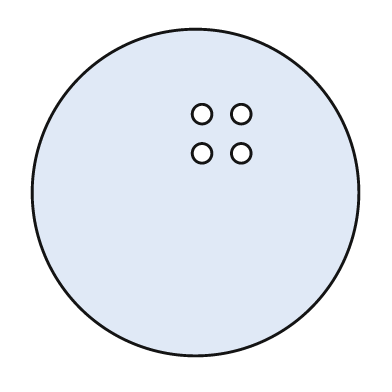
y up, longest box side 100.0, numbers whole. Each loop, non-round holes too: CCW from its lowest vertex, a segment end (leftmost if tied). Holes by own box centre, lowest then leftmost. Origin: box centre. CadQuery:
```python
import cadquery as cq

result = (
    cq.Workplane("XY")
    .moveTo(0.0, 0.0)
    .circle(50.0)
    .moveTo(2.0, 12.0)
    .circle(3.0)
    .moveTo(14.0, 12.0)
    .circle(3.0)
    .moveTo(2.0, 24.0)
    .circle(3.0)
    .moveTo(14.0, 24.0)
    .circle(3.0)
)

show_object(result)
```